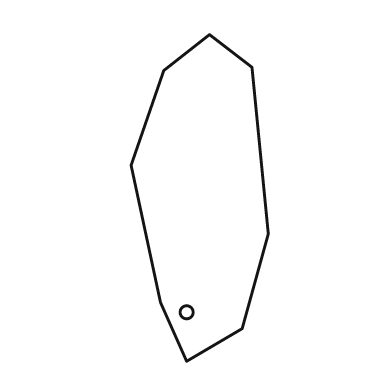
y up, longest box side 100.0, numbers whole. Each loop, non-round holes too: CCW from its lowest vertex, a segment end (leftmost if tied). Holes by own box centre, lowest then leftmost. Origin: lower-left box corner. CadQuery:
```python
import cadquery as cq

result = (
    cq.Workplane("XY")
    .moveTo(17.0, 0.0)
    .lineTo(34.0, 10.0)
    .lineTo(42.0, 39.0)
    .lineTo(37.0, 90.0)
    .lineTo(24.0, 100.0)
    .lineTo(10.0, 89.0)
    .lineTo(0.0, 60.0)
    .lineTo(9.0, 18.0)
    .close()
    .moveTo(17.0, 15.0)
    .circle(2.0)
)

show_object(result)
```